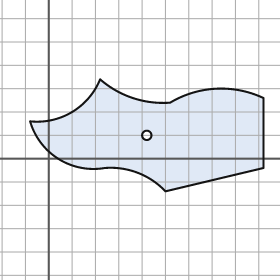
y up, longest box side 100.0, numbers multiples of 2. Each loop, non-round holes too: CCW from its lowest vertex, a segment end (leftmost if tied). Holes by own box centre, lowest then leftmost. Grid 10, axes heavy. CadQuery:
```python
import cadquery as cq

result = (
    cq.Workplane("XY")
    .moveTo(50.0, -14.0)
    .lineTo(92.0, -4.0)
    .lineTo(92.0, 26.0)
    .threePointArc((72.0, 30.0), (52.0, 24.0))
    .threePointArc((36.0, 26.0), (22.0, 34.0))
    .threePointArc((10.0, 20.0), (-8.0, 16.0))
    .threePointArc((4.0, 0.0), (24.0, -4.0))
    .threePointArc((38.0, -6.0), (50.0, -14.0))
    .close()
    .moveTo(42.0, 10.0)
    .circle(2.0)
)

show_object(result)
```